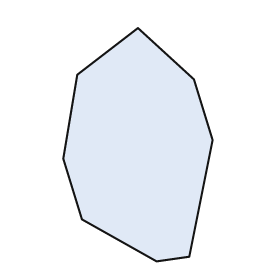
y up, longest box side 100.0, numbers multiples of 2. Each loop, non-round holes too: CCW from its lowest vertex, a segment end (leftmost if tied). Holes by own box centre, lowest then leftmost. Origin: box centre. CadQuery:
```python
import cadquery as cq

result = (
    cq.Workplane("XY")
    .moveTo(8.0, -50.0)
    .lineTo(22.0, -48.0)
    .lineTo(32.0, 2.0)
    .lineTo(24.0, 28.0)
    .lineTo(0.0, 50.0)
    .lineTo(-26.0, 30.0)
    .lineTo(-32.0, -6.0)
    .lineTo(-24.0, -32.0)
    .close()
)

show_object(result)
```